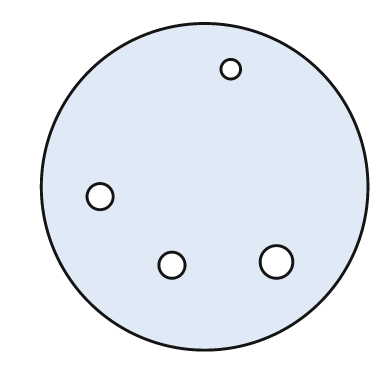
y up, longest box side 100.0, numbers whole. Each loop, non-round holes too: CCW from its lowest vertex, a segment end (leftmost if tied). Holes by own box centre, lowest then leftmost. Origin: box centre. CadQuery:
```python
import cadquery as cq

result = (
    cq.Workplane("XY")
    .moveTo(0.0, 0.0)
    .circle(50.0)
    .moveTo(-10.0, -24.0)
    .circle(4.0)
    .moveTo(22.0, -23.0)
    .circle(5.0)
    .moveTo(-32.0, -3.0)
    .circle(4.0)
    .moveTo(8.0, 36.0)
    .circle(3.0)
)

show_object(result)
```